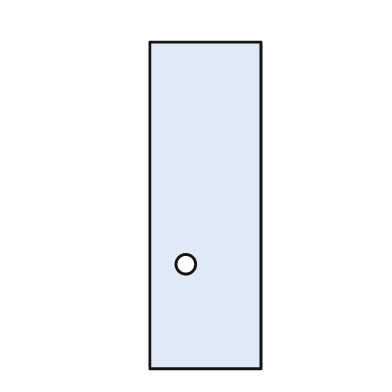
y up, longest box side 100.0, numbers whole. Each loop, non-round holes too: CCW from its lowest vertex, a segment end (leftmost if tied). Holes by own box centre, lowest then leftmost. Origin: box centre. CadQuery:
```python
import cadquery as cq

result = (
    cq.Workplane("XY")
    .moveTo(-17.0, -50.0)
    .lineTo(17.0, -50.0)
    .lineTo(17.0, 50.0)
    .lineTo(-17.0, 50.0)
    .close()
    .moveTo(-6.0, -18.0)
    .circle(3.0)
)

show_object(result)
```